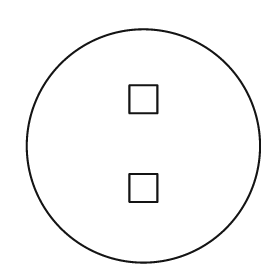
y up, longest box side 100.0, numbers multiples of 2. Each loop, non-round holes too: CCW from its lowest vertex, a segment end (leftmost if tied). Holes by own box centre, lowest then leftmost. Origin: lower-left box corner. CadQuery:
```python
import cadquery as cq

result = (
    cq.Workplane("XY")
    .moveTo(50.0, 50.0)
    .circle(50.0)
    .moveTo(44.0, 26.0)
    .lineTo(56.0, 26.0)
    .lineTo(56.0, 38.0)
    .lineTo(44.0, 38.0)
    .close()
    .moveTo(44.0, 64.0)
    .lineTo(56.0, 64.0)
    .lineTo(56.0, 76.0)
    .lineTo(44.0, 76.0)
    .close()
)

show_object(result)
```